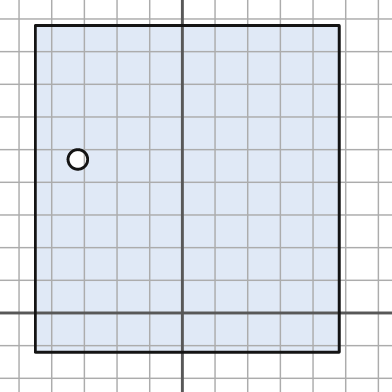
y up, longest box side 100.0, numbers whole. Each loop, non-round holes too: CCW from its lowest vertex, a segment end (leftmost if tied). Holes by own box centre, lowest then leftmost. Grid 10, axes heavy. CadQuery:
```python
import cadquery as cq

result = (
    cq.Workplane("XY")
    .moveTo(-45.0, -12.0)
    .lineTo(48.0, -12.0)
    .lineTo(48.0, 88.0)
    .lineTo(-45.0, 88.0)
    .close()
    .moveTo(-32.0, 47.0)
    .circle(3.0)
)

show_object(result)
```